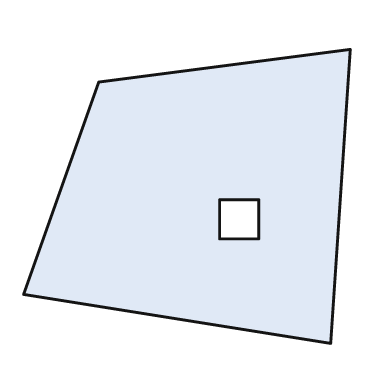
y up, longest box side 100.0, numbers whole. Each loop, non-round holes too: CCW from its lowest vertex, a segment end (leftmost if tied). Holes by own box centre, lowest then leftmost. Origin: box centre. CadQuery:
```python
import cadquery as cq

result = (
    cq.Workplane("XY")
    .moveTo(44.0, -45.0)
    .lineTo(50.0, 45.0)
    .lineTo(-27.0, 35.0)
    .lineTo(-50.0, -30.0)
    .close()
    .moveTo(10.0, -13.0)
    .lineTo(22.0, -13.0)
    .lineTo(22.0, -1.0)
    .lineTo(10.0, -1.0)
    .close()
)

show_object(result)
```